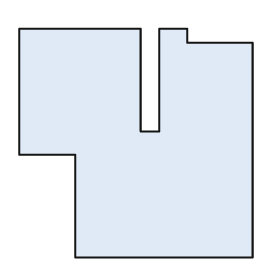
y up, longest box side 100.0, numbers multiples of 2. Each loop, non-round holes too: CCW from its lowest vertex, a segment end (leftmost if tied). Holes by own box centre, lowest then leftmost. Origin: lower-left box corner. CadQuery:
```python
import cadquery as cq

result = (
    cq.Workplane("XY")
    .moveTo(24.0, 0.0)
    .lineTo(100.0, 0.0)
    .lineTo(100.0, 92.0)
    .lineTo(72.0, 92.0)
    .lineTo(72.0, 98.0)
    .lineTo(60.0, 98.0)
    .lineTo(60.0, 54.0)
    .lineTo(52.0, 54.0)
    .lineTo(52.0, 98.0)
    .lineTo(0.0, 98.0)
    .lineTo(0.0, 44.0)
    .lineTo(24.0, 44.0)
    .close()
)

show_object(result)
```